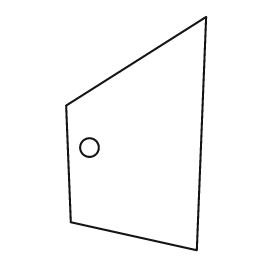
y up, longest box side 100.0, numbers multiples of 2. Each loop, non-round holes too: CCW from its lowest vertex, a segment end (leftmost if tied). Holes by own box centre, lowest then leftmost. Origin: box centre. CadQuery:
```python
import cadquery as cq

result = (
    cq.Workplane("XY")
    .moveTo(26.0, -50.0)
    .lineTo(30.0, 50.0)
    .lineTo(-30.0, 12.0)
    .lineTo(-28.0, -38.0)
    .close()
    .moveTo(-20.0, -6.0)
    .circle(4.0)
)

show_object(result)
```